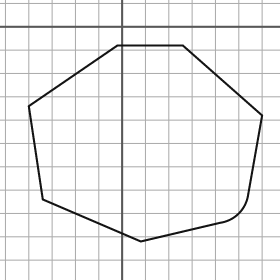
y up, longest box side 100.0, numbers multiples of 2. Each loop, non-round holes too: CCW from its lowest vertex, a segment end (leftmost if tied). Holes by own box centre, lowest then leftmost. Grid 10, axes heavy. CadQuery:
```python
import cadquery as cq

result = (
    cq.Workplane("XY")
    .moveTo(8.0, -92.0)
    .lineTo(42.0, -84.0)
    .threePointArc((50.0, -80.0), (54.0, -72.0))
    .lineTo(60.0, -38.0)
    .lineTo(26.0, -8.0)
    .lineTo(-2.0, -8.0)
    .lineTo(-40.0, -34.0)
    .lineTo(-34.0, -74.0)
    .close()
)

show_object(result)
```